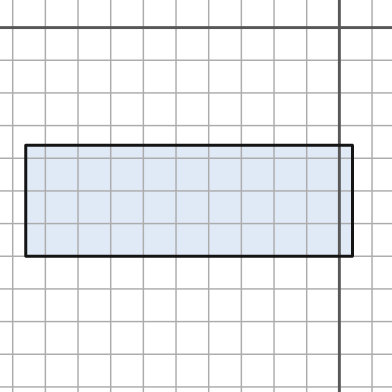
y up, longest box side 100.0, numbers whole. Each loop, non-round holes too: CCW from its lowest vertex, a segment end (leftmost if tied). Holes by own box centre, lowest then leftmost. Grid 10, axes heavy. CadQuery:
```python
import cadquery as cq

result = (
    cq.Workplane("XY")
    .moveTo(-96.0, -70.0)
    .lineTo(4.0, -70.0)
    .lineTo(4.0, -36.0)
    .lineTo(-96.0, -36.0)
    .close()
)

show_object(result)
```